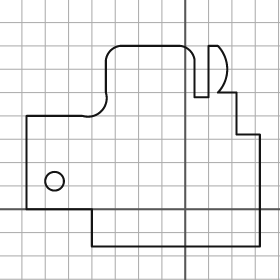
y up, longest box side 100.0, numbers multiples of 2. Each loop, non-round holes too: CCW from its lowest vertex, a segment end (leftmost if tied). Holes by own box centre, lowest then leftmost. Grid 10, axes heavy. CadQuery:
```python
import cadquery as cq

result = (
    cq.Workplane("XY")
    .moveTo(-40.0, -16.0)
    .lineTo(32.0, -16.0)
    .lineTo(32.0, 32.0)
    .lineTo(22.0, 32.0)
    .lineTo(22.0, 50.0)
    .lineTo(14.0, 50.0)
    .threePointArc((18.0, 60.0), (14.0, 70.0))
    .lineTo(10.0, 70.0)
    .lineTo(10.0, 48.0)
    .lineTo(4.0, 48.0)
    .lineTo(4.0, 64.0)
    .threePointArc((2.0, 68.0), (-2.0, 70.0))
    .lineTo(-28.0, 70.0)
    .threePointArc((-32.0, 68.0), (-34.0, 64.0))
    .lineTo(-34.0, 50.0)
    .threePointArc((-36.0, 42.0), (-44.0, 40.0))
    .lineTo(-68.0, 40.0)
    .lineTo(-68.0, 0.0)
    .lineTo(-40.0, 0.0)
    .close()
    .moveTo(-56.0, 12.0)
    .circle(4.0)
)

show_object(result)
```